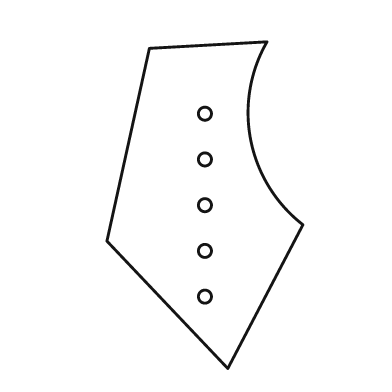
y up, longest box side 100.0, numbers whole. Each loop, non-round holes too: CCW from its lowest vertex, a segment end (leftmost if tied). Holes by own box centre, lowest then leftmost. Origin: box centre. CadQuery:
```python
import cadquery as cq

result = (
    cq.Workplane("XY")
    .moveTo(7.0, -50.0)
    .lineTo(30.0, -6.0)
    .threePointArc((14.0, 20.0), (19.0, 50.0))
    .lineTo(-17.0, 48.0)
    .lineTo(-30.0, -11.0)
    .close()
    .moveTo(0.0, -28.0)
    .circle(2.0)
    .moveTo(0.0, -14.0)
    .circle(2.0)
    .moveTo(0.0, 0.0)
    .circle(2.0)
    .moveTo(0.0, 14.0)
    .circle(2.0)
    .moveTo(0.0, 28.0)
    .circle(2.0)
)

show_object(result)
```